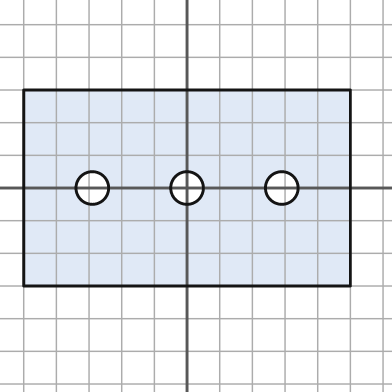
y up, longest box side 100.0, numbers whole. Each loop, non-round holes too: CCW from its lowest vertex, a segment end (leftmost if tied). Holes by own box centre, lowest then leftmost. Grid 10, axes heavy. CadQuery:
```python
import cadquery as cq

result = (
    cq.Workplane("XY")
    .moveTo(-50.0, -30.0)
    .lineTo(50.0, -30.0)
    .lineTo(50.0, 30.0)
    .lineTo(-50.0, 30.0)
    .close()
    .moveTo(-29.0, 0.0)
    .circle(5.0)
    .moveTo(0.0, 0.0)
    .circle(5.0)
    .moveTo(29.0, 0.0)
    .circle(5.0)
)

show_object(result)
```